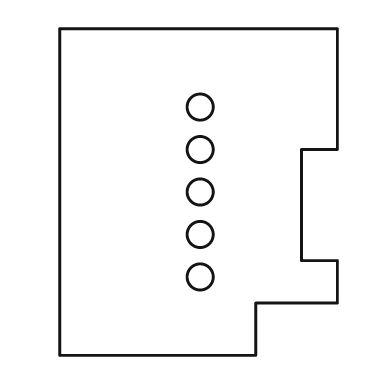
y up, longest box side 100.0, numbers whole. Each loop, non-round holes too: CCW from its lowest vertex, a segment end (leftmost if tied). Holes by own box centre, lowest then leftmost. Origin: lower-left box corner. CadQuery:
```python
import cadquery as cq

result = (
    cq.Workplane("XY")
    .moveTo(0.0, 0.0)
    .lineTo(60.0, 0.0)
    .lineTo(60.0, 16.0)
    .lineTo(85.0, 16.0)
    .lineTo(85.0, 29.0)
    .lineTo(74.0, 29.0)
    .lineTo(74.0, 63.0)
    .lineTo(85.0, 63.0)
    .lineTo(85.0, 100.0)
    .lineTo(0.0, 100.0)
    .close()
    .moveTo(43.0, 24.0)
    .circle(4.0)
    .moveTo(43.0, 37.0)
    .circle(4.0)
    .moveTo(43.0, 50.0)
    .circle(4.0)
    .moveTo(43.0, 63.0)
    .circle(4.0)
    .moveTo(43.0, 76.0)
    .circle(4.0)
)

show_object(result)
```